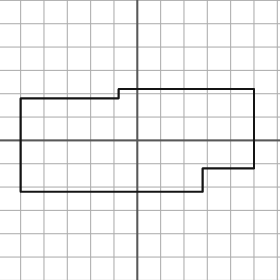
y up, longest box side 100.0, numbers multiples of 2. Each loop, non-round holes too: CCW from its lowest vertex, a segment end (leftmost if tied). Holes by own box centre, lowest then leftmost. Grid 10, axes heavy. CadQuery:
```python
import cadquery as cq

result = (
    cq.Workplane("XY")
    .moveTo(-50.0, -22.0)
    .lineTo(28.0, -22.0)
    .lineTo(28.0, -12.0)
    .lineTo(50.0, -12.0)
    .lineTo(50.0, 22.0)
    .lineTo(-8.0, 22.0)
    .lineTo(-8.0, 18.0)
    .lineTo(-50.0, 18.0)
    .close()
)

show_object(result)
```